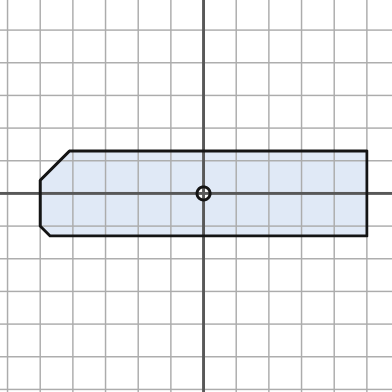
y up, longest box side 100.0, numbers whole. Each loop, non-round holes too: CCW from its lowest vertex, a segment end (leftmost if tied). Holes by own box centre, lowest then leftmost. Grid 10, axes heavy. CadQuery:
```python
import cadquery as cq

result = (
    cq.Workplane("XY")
    .moveTo(-47.0, -13.0)
    .lineTo(50.0, -13.0)
    .lineTo(50.0, 13.0)
    .lineTo(-41.0, 13.0)
    .lineTo(-50.0, 4.0)
    .lineTo(-50.0, -10.0)
    .close()
    .moveTo(0.0, 0.0)
    .circle(2.0)
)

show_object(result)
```